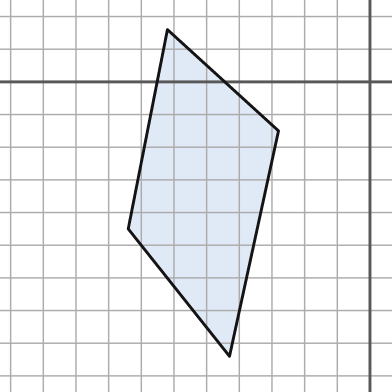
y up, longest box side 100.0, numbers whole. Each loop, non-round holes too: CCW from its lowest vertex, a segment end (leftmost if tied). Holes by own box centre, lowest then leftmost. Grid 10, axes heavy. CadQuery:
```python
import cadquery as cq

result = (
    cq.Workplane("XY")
    .moveTo(-43.0, -84.0)
    .lineTo(-28.0, -15.0)
    .lineTo(-62.0, 16.0)
    .lineTo(-74.0, -45.0)
    .close()
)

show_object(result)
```